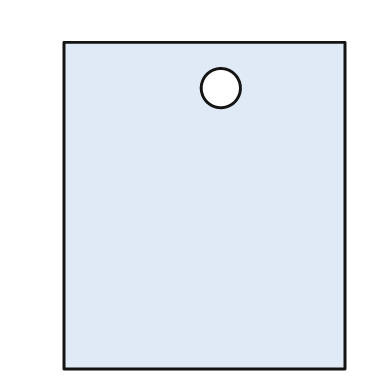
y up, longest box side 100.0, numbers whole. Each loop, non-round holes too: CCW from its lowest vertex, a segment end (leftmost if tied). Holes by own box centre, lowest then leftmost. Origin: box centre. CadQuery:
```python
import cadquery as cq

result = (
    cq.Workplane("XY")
    .moveTo(-43.0, -50.0)
    .lineTo(43.0, -50.0)
    .lineTo(43.0, 50.0)
    .lineTo(-43.0, 50.0)
    .close()
    .moveTo(5.0, 36.0)
    .circle(6.0)
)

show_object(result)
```